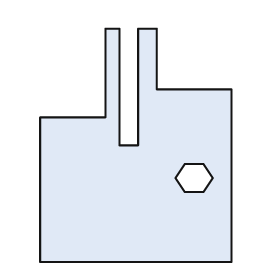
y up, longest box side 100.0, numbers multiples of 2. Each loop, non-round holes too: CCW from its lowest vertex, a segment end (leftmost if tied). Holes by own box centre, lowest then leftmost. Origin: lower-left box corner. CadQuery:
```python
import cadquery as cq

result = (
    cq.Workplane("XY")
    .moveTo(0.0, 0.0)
    .lineTo(82.0, 0.0)
    .lineTo(82.0, 74.0)
    .lineTo(50.0, 74.0)
    .lineTo(50.0, 100.0)
    .lineTo(42.0, 100.0)
    .lineTo(42.0, 50.0)
    .lineTo(34.0, 50.0)
    .lineTo(34.0, 100.0)
    .lineTo(28.0, 100.0)
    .lineTo(28.0, 62.0)
    .lineTo(0.0, 62.0)
    .close()
    .moveTo(62.0, 30.0)
    .lineTo(70.0, 30.0)
    .lineTo(74.0, 36.0)
    .lineTo(70.0, 42.0)
    .lineTo(62.0, 42.0)
    .lineTo(58.0, 36.0)
    .close()
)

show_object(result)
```